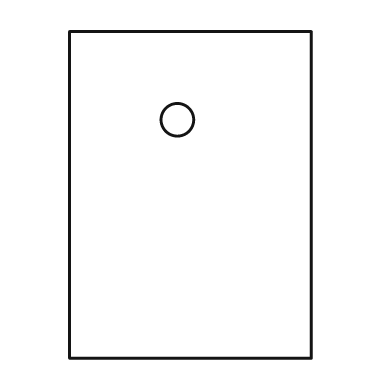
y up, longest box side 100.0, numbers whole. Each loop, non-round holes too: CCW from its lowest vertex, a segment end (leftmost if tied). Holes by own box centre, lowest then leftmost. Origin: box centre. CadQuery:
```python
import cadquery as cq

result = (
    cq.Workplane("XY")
    .moveTo(-37.0, -50.0)
    .lineTo(37.0, -50.0)
    .lineTo(37.0, 50.0)
    .lineTo(-37.0, 50.0)
    .close()
    .moveTo(-4.0, 23.0)
    .circle(5.0)
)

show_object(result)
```